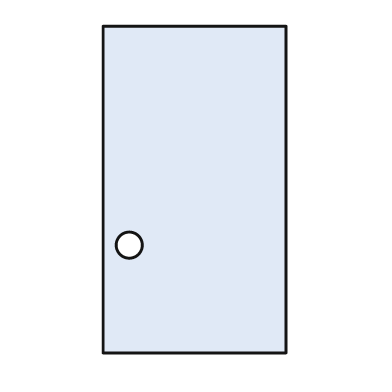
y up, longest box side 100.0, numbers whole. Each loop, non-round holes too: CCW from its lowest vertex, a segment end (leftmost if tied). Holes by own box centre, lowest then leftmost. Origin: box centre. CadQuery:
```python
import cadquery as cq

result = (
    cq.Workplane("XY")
    .moveTo(-28.0, -50.0)
    .lineTo(28.0, -50.0)
    .lineTo(28.0, 50.0)
    .lineTo(-28.0, 50.0)
    .close()
    .moveTo(-20.0, -17.0)
    .circle(4.0)
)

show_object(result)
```